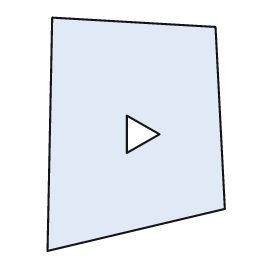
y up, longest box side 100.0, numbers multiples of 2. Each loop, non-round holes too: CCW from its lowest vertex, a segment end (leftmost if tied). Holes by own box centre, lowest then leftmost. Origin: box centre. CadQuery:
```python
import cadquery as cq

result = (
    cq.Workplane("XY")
    .moveTo(-38.0, -50.0)
    .lineTo(38.0, -32.0)
    .lineTo(34.0, 46.0)
    .lineTo(-36.0, 50.0)
    .close()
    .moveTo(-4.0, -8.0)
    .lineTo(10.0, 0.0)
    .lineTo(-4.0, 8.0)
    .close()
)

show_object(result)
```